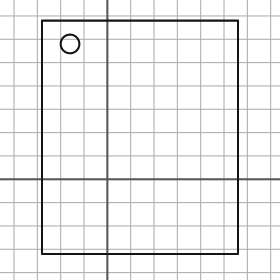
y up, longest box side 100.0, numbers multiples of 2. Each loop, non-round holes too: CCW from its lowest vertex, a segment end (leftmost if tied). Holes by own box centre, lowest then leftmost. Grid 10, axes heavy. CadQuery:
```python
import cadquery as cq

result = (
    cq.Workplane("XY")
    .moveTo(-28.0, -32.0)
    .lineTo(56.0, -32.0)
    .lineTo(56.0, 68.0)
    .lineTo(-28.0, 68.0)
    .close()
    .moveTo(-16.0, 58.0)
    .circle(4.0)
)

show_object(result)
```